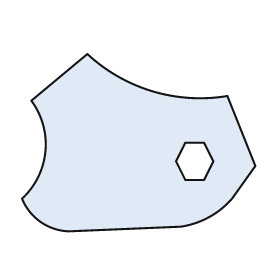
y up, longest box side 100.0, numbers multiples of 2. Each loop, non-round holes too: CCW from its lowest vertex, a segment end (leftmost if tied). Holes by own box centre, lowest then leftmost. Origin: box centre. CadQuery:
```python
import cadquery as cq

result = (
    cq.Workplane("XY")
    .moveTo(-30.0, -38.0)
    .lineTo(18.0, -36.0)
    .threePointArc((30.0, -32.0), (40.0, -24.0))
    .lineTo(50.0, -10.0)
    .lineTo(38.0, 20.0)
    .threePointArc((6.0, 22.0), (-22.0, 38.0))
    .lineTo(-46.0, 18.0)
    .threePointArc((-40.0, -4.0), (-50.0, -24.0))
    .threePointArc((-42.0, -34.0), (-30.0, -38.0))
    .close()
    .moveTo(20.0, -16.0)
    .lineTo(28.0, -16.0)
    .lineTo(32.0, -8.0)
    .lineTo(28.0, 0.0)
    .lineTo(20.0, 0.0)
    .lineTo(16.0, -8.0)
    .close()
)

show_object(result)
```